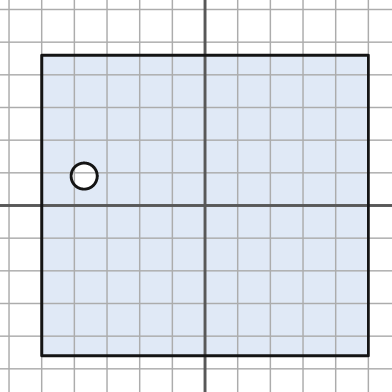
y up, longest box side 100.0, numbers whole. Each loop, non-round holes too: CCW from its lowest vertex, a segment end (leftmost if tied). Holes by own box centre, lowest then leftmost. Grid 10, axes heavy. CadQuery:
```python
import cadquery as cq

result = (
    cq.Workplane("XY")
    .moveTo(-50.0, -46.0)
    .lineTo(50.0, -46.0)
    .lineTo(50.0, 46.0)
    .lineTo(-50.0, 46.0)
    .close()
    .moveTo(-37.0, 9.0)
    .circle(4.0)
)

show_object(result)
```